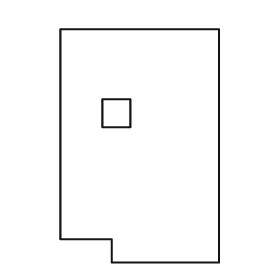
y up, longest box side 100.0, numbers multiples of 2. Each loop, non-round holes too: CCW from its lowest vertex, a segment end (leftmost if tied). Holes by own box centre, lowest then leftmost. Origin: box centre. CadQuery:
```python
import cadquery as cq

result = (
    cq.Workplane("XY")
    .moveTo(-12.0, -50.0)
    .lineTo(34.0, -50.0)
    .lineTo(34.0, 50.0)
    .lineTo(-34.0, 50.0)
    .lineTo(-34.0, -40.0)
    .lineTo(-12.0, -40.0)
    .close()
    .moveTo(-16.0, 8.0)
    .lineTo(-4.0, 8.0)
    .lineTo(-4.0, 20.0)
    .lineTo(-16.0, 20.0)
    .close()
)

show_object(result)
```